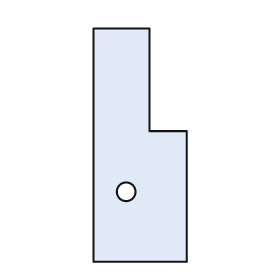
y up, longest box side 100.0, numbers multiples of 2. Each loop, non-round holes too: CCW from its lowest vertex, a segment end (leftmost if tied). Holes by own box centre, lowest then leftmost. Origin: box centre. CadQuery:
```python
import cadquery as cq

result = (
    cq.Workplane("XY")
    .moveTo(-20.0, -50.0)
    .lineTo(20.0, -50.0)
    .lineTo(20.0, 6.0)
    .lineTo(4.0, 6.0)
    .lineTo(4.0, 50.0)
    .lineTo(-20.0, 50.0)
    .close()
    .moveTo(-6.0, -20.0)
    .circle(4.0)
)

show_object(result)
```